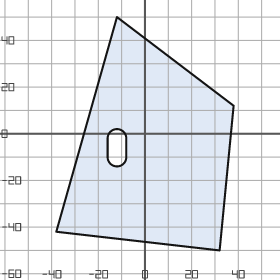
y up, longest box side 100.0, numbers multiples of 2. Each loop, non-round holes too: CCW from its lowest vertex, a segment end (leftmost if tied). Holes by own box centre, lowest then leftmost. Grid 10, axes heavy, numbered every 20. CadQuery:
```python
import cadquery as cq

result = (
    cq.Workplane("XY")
    .moveTo(32.0, -50.0)
    .lineTo(38.0, 12.0)
    .lineTo(-12.0, 50.0)
    .lineTo(-38.0, -42.0)
    .close()
    .moveTo(-16.0, -10.0)
    .threePointArc((-12.0, -14.0), (-8.0, -10.0))
    .lineTo(-8.0, -2.0)
    .threePointArc((-12.0, 2.0), (-16.0, -2.0))
    .close()
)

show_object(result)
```